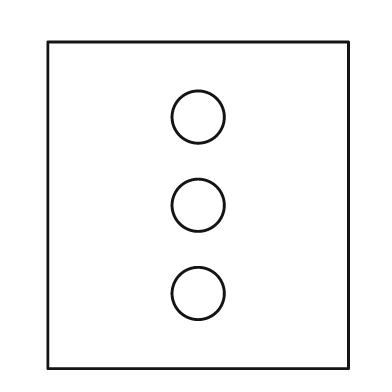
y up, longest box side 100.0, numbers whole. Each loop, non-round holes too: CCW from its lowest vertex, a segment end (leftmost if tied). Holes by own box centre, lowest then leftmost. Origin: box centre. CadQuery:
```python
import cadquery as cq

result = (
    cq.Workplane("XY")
    .moveTo(-46.0, -50.0)
    .lineTo(46.0, -50.0)
    .lineTo(46.0, 50.0)
    .lineTo(-46.0, 50.0)
    .close()
    .moveTo(0.0, -27.0)
    .circle(8.0)
    .moveTo(0.0, 0.0)
    .circle(8.0)
    .moveTo(0.0, 27.0)
    .circle(8.0)
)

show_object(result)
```